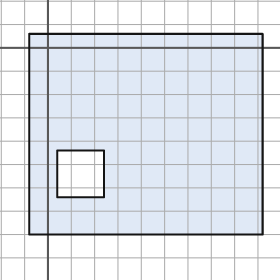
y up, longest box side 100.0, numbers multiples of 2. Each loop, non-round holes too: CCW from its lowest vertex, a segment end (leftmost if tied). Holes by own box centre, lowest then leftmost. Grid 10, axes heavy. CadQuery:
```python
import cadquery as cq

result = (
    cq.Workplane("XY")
    .moveTo(-8.0, -80.0)
    .lineTo(92.0, -80.0)
    .lineTo(92.0, 6.0)
    .lineTo(-8.0, 6.0)
    .close()
    .moveTo(4.0, -64.0)
    .lineTo(24.0, -64.0)
    .lineTo(24.0, -44.0)
    .lineTo(4.0, -44.0)
    .close()
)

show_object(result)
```